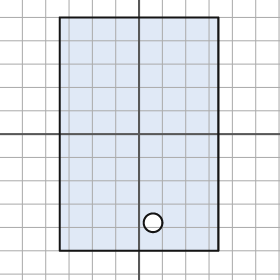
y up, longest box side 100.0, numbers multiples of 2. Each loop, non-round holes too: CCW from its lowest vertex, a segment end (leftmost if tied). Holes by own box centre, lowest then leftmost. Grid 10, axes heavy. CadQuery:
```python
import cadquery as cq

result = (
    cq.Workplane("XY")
    .moveTo(-34.0, -50.0)
    .lineTo(34.0, -50.0)
    .lineTo(34.0, 50.0)
    .lineTo(-34.0, 50.0)
    .close()
    .moveTo(6.0, -38.0)
    .circle(4.0)
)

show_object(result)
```